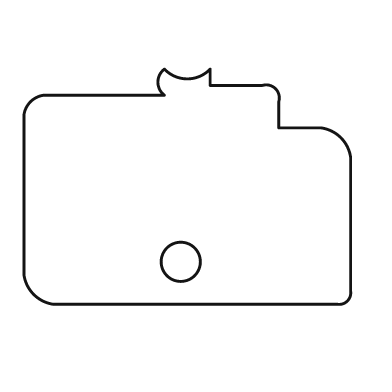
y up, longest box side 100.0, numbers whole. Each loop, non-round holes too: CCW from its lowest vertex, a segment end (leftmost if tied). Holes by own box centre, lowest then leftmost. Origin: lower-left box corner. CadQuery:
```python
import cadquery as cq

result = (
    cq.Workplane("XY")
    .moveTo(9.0, 0.0)
    .lineTo(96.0, 0.0)
    .threePointArc((99.0, 1.0), (100.0, 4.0))
    .lineTo(100.0, 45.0)
    .threePointArc((97.0, 51.0), (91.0, 54.0))
    .lineTo(78.0, 54.0)
    .lineTo(78.0, 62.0)
    .threePointArc((77.0, 66.0), (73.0, 67.0))
    .lineTo(57.0, 67.0)
    .lineTo(57.0, 72.0)
    .threePointArc((50.0, 69.0), (43.0, 72.0))
    .threePointArc((41.0, 68.0), (43.0, 64.0))
    .lineTo(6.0, 64.0)
    .threePointArc((2.0, 62.0), (0.0, 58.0))
    .lineTo(0.0, 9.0)
    .threePointArc((3.0, 3.0), (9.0, 0.0))
    .close()
    .moveTo(48.0, 13.0)
    .circle(6.0)
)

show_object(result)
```